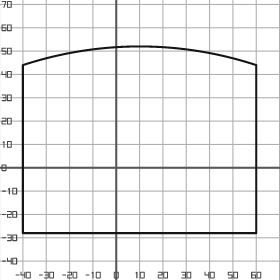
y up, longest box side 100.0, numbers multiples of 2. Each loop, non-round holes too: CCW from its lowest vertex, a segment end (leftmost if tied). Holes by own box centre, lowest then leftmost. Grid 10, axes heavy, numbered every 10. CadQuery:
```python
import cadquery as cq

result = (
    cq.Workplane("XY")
    .moveTo(-40.0, -28.0)
    .lineTo(60.0, -28.0)
    .lineTo(60.0, 44.0)
    .threePointArc((10.0, 52.0), (-40.0, 44.0))
    .close()
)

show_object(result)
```